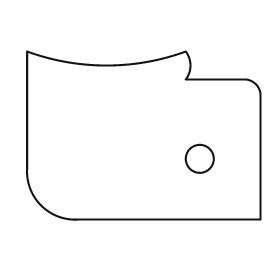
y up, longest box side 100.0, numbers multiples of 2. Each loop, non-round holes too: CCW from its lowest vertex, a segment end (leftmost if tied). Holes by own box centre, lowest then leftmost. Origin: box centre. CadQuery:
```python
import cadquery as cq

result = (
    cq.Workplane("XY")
    .moveTo(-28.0, -36.0)
    .lineTo(50.0, -36.0)
    .lineTo(50.0, 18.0)
    .threePointArc((48.0, 22.0), (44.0, 24.0))
    .lineTo(18.0, 24.0)
    .threePointArc((20.0, 30.0), (18.0, 36.0))
    .threePointArc((-16.0, 30.0), (-50.0, 36.0))
    .lineTo(-50.0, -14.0)
    .threePointArc((-44.0, -30.0), (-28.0, -36.0))
    .close()
    .moveTo(24.0, -10.0)
    .circle(6.0)
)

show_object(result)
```